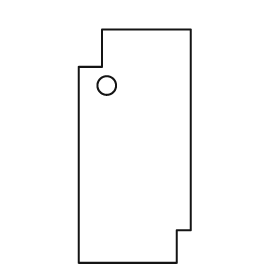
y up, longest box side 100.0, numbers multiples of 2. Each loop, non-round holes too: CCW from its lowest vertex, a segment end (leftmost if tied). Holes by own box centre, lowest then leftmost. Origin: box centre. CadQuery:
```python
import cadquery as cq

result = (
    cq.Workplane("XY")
    .moveTo(-24.0, -50.0)
    .lineTo(18.0, -50.0)
    .lineTo(18.0, -36.0)
    .lineTo(24.0, -36.0)
    .lineTo(24.0, 50.0)
    .lineTo(-14.0, 50.0)
    .lineTo(-14.0, 34.0)
    .lineTo(-24.0, 34.0)
    .close()
    .moveTo(-12.0, 26.0)
    .circle(4.0)
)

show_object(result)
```